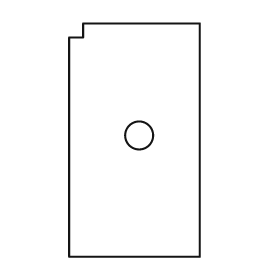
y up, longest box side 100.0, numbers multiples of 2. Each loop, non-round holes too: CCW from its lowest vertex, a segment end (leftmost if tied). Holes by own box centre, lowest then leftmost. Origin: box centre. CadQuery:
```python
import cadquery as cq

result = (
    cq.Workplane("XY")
    .moveTo(-28.0, -50.0)
    .lineTo(28.0, -50.0)
    .lineTo(28.0, 50.0)
    .lineTo(-22.0, 50.0)
    .lineTo(-22.0, 44.0)
    .lineTo(-28.0, 44.0)
    .close()
    .moveTo(2.0, 2.0)
    .circle(6.0)
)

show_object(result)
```